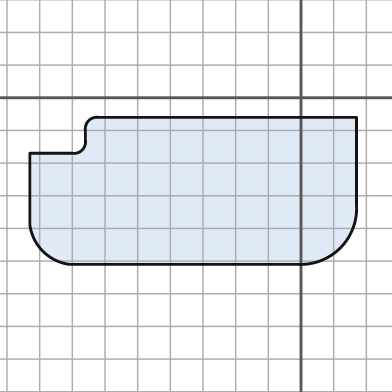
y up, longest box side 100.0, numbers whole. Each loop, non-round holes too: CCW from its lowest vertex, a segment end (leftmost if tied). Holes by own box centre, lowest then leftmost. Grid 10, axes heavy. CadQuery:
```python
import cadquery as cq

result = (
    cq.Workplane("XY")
    .moveTo(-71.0, -51.0)
    .lineTo(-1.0, -51.0)
    .threePointArc((12.0, -46.0), (17.0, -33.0))
    .lineTo(17.0, -6.0)
    .lineTo(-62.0, -6.0)
    .threePointArc((-65.0, -7.0), (-66.0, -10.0))
    .lineTo(-66.0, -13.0)
    .threePointArc((-67.0, -16.0), (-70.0, -17.0))
    .lineTo(-83.0, -17.0)
    .lineTo(-83.0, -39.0)
    .threePointArc((-79.0, -47.0), (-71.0, -51.0))
    .close()
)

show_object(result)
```